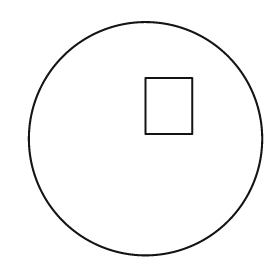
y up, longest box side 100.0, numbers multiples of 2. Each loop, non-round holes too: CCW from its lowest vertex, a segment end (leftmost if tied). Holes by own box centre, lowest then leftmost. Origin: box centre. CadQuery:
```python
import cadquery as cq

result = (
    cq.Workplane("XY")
    .moveTo(0.0, 0.0)
    .circle(50.0)
    .moveTo(0.0, 2.0)
    .lineTo(20.0, 2.0)
    .lineTo(20.0, 26.0)
    .lineTo(0.0, 26.0)
    .close()
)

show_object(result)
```